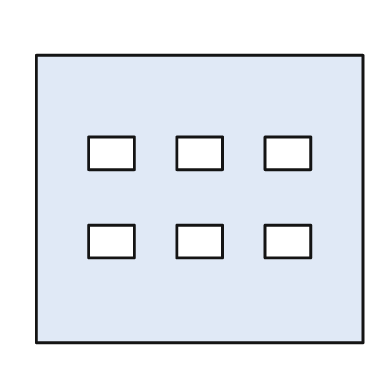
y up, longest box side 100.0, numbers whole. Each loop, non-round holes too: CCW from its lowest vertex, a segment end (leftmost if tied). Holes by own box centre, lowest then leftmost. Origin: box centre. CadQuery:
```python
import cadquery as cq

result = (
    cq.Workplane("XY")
    .moveTo(-50.0, -44.0)
    .lineTo(50.0, -44.0)
    .lineTo(50.0, 44.0)
    .lineTo(-50.0, 44.0)
    .close()
    .moveTo(-34.0, -18.0)
    .lineTo(-20.0, -18.0)
    .lineTo(-20.0, -8.0)
    .lineTo(-34.0, -8.0)
    .close()
    .moveTo(-7.0, -18.0)
    .lineTo(7.0, -18.0)
    .lineTo(7.0, -8.0)
    .lineTo(-7.0, -8.0)
    .close()
    .moveTo(20.0, -18.0)
    .lineTo(34.0, -18.0)
    .lineTo(34.0, -8.0)
    .lineTo(20.0, -8.0)
    .close()
    .moveTo(-34.0, 9.0)
    .lineTo(-20.0, 9.0)
    .lineTo(-20.0, 19.0)
    .lineTo(-34.0, 19.0)
    .close()
    .moveTo(-7.0, 9.0)
    .lineTo(7.0, 9.0)
    .lineTo(7.0, 19.0)
    .lineTo(-7.0, 19.0)
    .close()
    .moveTo(20.0, 9.0)
    .lineTo(34.0, 9.0)
    .lineTo(34.0, 19.0)
    .lineTo(20.0, 19.0)
    .close()
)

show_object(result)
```